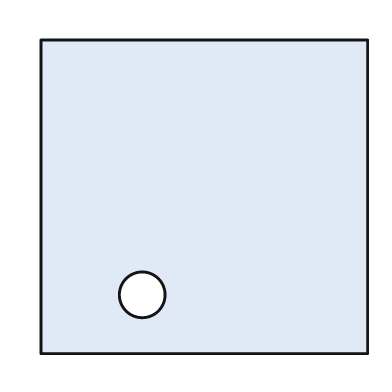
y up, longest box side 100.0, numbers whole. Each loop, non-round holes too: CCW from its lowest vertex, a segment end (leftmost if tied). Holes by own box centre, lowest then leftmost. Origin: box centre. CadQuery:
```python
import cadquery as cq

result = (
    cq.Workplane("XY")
    .moveTo(-50.0, -48.0)
    .lineTo(50.0, -48.0)
    .lineTo(50.0, 48.0)
    .lineTo(-50.0, 48.0)
    .close()
    .moveTo(-19.0, -30.0)
    .circle(7.0)
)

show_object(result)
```